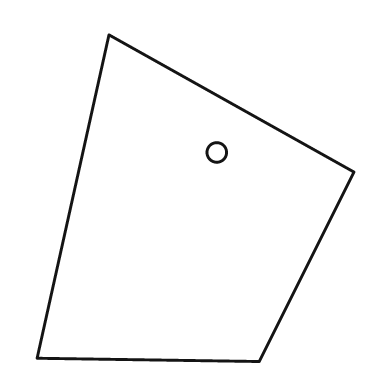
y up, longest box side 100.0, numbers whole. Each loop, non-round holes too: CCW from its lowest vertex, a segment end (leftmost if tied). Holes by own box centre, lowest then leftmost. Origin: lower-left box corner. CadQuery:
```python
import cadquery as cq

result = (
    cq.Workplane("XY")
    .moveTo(68.0, 0.0)
    .lineTo(97.0, 58.0)
    .lineTo(22.0, 100.0)
    .lineTo(0.0, 1.0)
    .close()
    .moveTo(55.0, 64.0)
    .circle(3.0)
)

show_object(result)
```